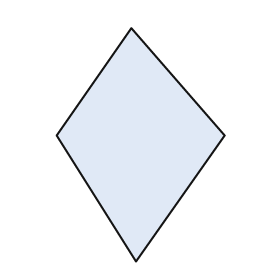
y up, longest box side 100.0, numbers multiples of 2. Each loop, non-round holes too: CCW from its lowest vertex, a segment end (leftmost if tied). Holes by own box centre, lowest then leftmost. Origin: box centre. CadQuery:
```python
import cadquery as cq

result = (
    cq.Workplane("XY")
    .moveTo(-2.0, -50.0)
    .lineTo(36.0, 4.0)
    .lineTo(-4.0, 50.0)
    .lineTo(-36.0, 4.0)
    .close()
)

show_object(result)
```